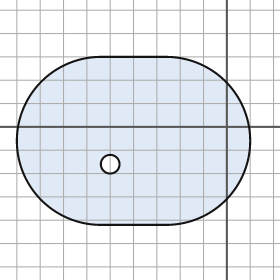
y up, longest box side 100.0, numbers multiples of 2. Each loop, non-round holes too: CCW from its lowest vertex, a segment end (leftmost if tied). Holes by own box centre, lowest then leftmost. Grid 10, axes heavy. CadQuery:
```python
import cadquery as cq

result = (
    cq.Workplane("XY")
    .moveTo(-54.0, -42.0)
    .lineTo(-26.0, -42.0)
    .threePointArc((10.0, -6.0), (-26.0, 30.0))
    .lineTo(-54.0, 30.0)
    .threePointArc((-90.0, -6.0), (-54.0, -42.0))
    .close()
    .moveTo(-50.0, -16.0)
    .circle(4.0)
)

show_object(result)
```